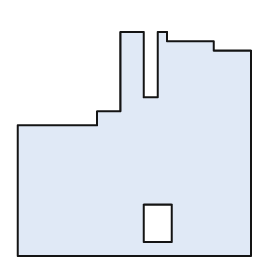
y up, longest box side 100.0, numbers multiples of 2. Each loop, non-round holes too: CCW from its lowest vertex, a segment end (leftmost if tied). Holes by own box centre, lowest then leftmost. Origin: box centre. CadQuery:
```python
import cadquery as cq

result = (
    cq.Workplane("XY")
    .moveTo(-50.0, -48.0)
    .lineTo(50.0, -48.0)
    .lineTo(50.0, 40.0)
    .lineTo(34.0, 40.0)
    .lineTo(34.0, 44.0)
    .lineTo(14.0, 44.0)
    .lineTo(14.0, 48.0)
    .lineTo(10.0, 48.0)
    .lineTo(10.0, 20.0)
    .lineTo(4.0, 20.0)
    .lineTo(4.0, 48.0)
    .lineTo(-6.0, 48.0)
    .lineTo(-6.0, 14.0)
    .lineTo(-16.0, 14.0)
    .lineTo(-16.0, 8.0)
    .lineTo(-50.0, 8.0)
    .close()
    .moveTo(4.0, -42.0)
    .lineTo(16.0, -42.0)
    .lineTo(16.0, -26.0)
    .lineTo(4.0, -26.0)
    .close()
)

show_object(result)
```